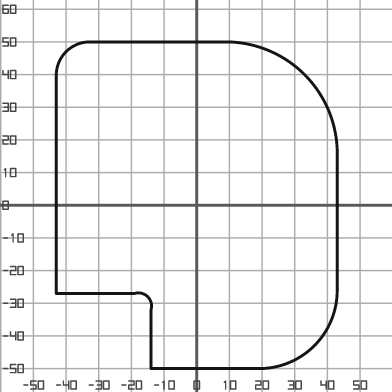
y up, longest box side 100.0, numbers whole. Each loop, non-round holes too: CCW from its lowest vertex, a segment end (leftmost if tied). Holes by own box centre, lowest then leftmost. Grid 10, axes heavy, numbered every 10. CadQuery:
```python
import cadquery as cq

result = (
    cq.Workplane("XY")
    .moveTo(-14.0, -50.0)
    .lineTo(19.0, -50.0)
    .threePointArc((36.0, -43.0), (43.0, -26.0))
    .lineTo(43.0, 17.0)
    .threePointArc((33.0, 40.0), (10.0, 50.0))
    .lineTo(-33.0, 50.0)
    .threePointArc((-40.0, 47.0), (-43.0, 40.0))
    .lineTo(-43.0, -27.0)
    .lineTo(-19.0, -27.0)
    .threePointArc((-15.0, -28.0), (-14.0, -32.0))
    .close()
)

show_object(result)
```